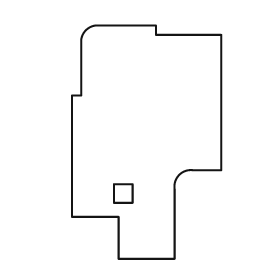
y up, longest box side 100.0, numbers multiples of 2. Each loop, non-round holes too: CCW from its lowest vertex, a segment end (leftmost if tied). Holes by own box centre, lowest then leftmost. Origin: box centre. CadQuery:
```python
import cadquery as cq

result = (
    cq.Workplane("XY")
    .moveTo(-12.0, -50.0)
    .lineTo(12.0, -50.0)
    .lineTo(12.0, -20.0)
    .threePointArc((14.0, -14.0), (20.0, -12.0))
    .lineTo(32.0, -12.0)
    .lineTo(32.0, 46.0)
    .lineTo(4.0, 46.0)
    .lineTo(4.0, 50.0)
    .lineTo(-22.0, 50.0)
    .threePointArc((-26.0, 48.0), (-28.0, 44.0))
    .lineTo(-28.0, 20.0)
    .lineTo(-32.0, 20.0)
    .lineTo(-32.0, -32.0)
    .lineTo(-12.0, -32.0)
    .close()
    .moveTo(-14.0, -26.0)
    .lineTo(-6.0, -26.0)
    .lineTo(-6.0, -18.0)
    .lineTo(-14.0, -18.0)
    .close()
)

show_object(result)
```